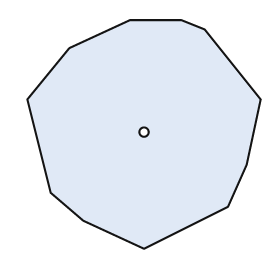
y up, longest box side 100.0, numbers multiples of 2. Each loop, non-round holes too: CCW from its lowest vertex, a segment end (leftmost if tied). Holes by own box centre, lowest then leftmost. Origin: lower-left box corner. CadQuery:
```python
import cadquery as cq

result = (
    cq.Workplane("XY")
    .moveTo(50.0, 0.0)
    .lineTo(86.0, 18.0)
    .lineTo(94.0, 36.0)
    .lineTo(100.0, 64.0)
    .lineTo(76.0, 94.0)
    .lineTo(66.0, 98.0)
    .lineTo(44.0, 98.0)
    .lineTo(18.0, 86.0)
    .lineTo(0.0, 64.0)
    .lineTo(10.0, 24.0)
    .lineTo(24.0, 12.0)
    .close()
    .moveTo(50.0, 50.0)
    .circle(2.0)
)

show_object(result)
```